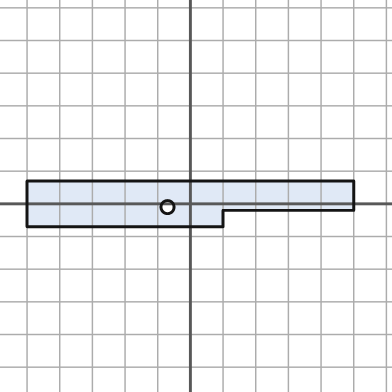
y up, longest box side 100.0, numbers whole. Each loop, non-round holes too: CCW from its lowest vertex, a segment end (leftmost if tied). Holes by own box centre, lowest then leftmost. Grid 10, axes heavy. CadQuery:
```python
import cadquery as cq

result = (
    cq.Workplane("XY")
    .moveTo(-50.0, -7.0)
    .lineTo(10.0, -7.0)
    .lineTo(10.0, -2.0)
    .lineTo(50.0, -2.0)
    .lineTo(50.0, 7.0)
    .lineTo(-50.0, 7.0)
    .close()
    .moveTo(-7.0, -1.0)
    .circle(2.0)
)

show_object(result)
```